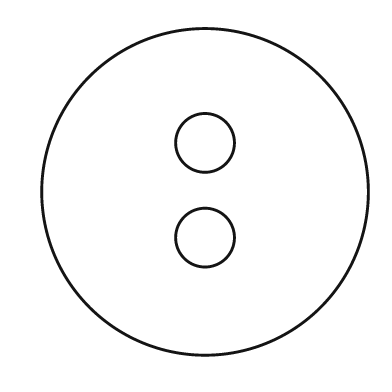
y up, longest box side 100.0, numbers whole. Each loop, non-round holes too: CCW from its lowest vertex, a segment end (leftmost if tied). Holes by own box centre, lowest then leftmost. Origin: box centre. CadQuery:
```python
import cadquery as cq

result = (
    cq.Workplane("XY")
    .moveTo(0.0, 0.0)
    .circle(50.0)
    .moveTo(0.0, -14.0)
    .circle(9.0)
    .moveTo(0.0, 15.0)
    .circle(9.0)
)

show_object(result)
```